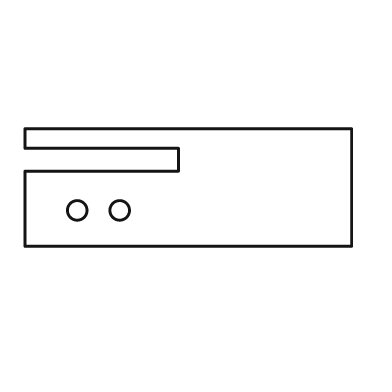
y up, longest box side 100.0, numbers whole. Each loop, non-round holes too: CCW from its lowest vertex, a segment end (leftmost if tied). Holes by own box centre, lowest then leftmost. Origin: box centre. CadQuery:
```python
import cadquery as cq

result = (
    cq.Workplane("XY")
    .moveTo(-50.0, -18.0)
    .lineTo(50.0, -18.0)
    .lineTo(50.0, 18.0)
    .lineTo(-50.0, 18.0)
    .lineTo(-50.0, 12.0)
    .lineTo(-3.0, 12.0)
    .lineTo(-3.0, 5.0)
    .lineTo(-50.0, 5.0)
    .close()
    .moveTo(-34.0, -7.0)
    .circle(3.0)
    .moveTo(-21.0, -7.0)
    .circle(3.0)
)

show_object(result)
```